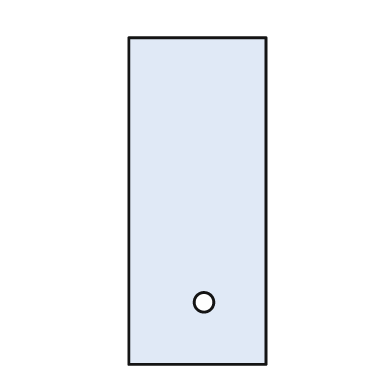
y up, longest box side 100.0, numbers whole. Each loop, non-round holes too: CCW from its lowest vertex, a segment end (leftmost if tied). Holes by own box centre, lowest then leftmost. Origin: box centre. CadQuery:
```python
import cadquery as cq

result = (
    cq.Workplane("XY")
    .moveTo(-21.0, -50.0)
    .lineTo(21.0, -50.0)
    .lineTo(21.0, 50.0)
    .lineTo(-21.0, 50.0)
    .close()
    .moveTo(2.0, -31.0)
    .circle(3.0)
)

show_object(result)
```